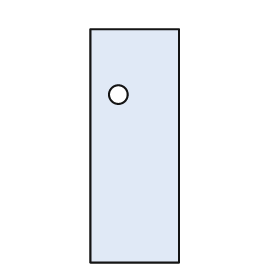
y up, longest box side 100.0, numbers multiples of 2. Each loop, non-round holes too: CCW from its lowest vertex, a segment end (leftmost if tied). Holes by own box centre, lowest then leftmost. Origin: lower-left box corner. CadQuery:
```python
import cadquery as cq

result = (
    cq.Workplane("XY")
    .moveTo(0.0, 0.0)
    .lineTo(38.0, 0.0)
    .lineTo(38.0, 100.0)
    .lineTo(0.0, 100.0)
    .close()
    .moveTo(12.0, 72.0)
    .circle(4.0)
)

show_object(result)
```